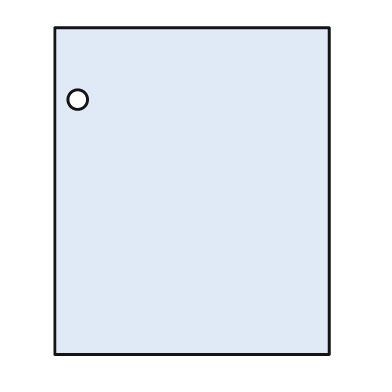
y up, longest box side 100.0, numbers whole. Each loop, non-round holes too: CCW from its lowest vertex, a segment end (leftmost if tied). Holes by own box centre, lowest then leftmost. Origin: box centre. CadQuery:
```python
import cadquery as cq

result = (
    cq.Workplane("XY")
    .moveTo(-42.0, -50.0)
    .lineTo(42.0, -50.0)
    .lineTo(42.0, 50.0)
    .lineTo(-42.0, 50.0)
    .close()
    .moveTo(-35.0, 28.0)
    .circle(3.0)
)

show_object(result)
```